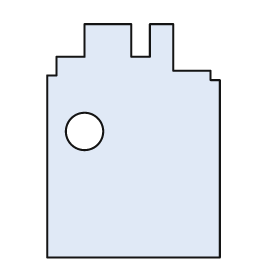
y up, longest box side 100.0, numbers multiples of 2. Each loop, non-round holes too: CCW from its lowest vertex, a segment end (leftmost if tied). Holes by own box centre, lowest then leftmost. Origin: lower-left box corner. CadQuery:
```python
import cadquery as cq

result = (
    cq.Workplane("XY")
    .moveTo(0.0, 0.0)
    .lineTo(74.0, 0.0)
    .lineTo(74.0, 76.0)
    .lineTo(70.0, 76.0)
    .lineTo(70.0, 80.0)
    .lineTo(54.0, 80.0)
    .lineTo(54.0, 100.0)
    .lineTo(44.0, 100.0)
    .lineTo(44.0, 86.0)
    .lineTo(36.0, 86.0)
    .lineTo(36.0, 100.0)
    .lineTo(16.0, 100.0)
    .lineTo(16.0, 86.0)
    .lineTo(4.0, 86.0)
    .lineTo(4.0, 78.0)
    .lineTo(0.0, 78.0)
    .close()
    .moveTo(16.0, 54.0)
    .circle(8.0)
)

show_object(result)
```